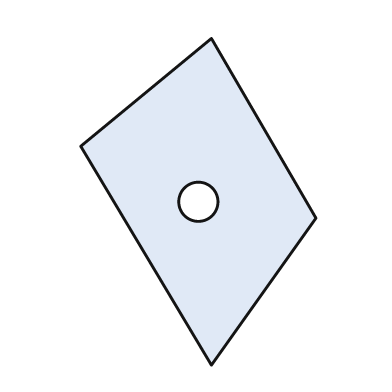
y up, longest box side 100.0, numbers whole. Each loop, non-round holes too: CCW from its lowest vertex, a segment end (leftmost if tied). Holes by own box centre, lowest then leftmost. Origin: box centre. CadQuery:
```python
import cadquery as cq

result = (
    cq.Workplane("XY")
    .moveTo(4.0, -50.0)
    .lineTo(36.0, -5.0)
    .lineTo(4.0, 50.0)
    .lineTo(-36.0, 17.0)
    .close()
    .moveTo(0.0, 0.0)
    .circle(6.0)
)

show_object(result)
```